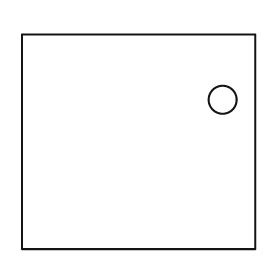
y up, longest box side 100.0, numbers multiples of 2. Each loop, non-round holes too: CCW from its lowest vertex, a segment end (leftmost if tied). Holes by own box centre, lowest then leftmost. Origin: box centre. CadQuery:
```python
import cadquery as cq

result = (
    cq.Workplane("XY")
    .moveTo(-50.0, -46.0)
    .lineTo(50.0, -46.0)
    .lineTo(50.0, 46.0)
    .lineTo(-50.0, 46.0)
    .close()
    .moveTo(36.0, 18.0)
    .circle(6.0)
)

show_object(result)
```